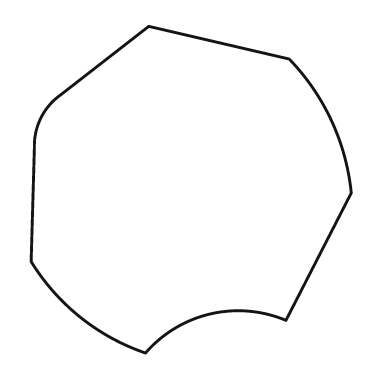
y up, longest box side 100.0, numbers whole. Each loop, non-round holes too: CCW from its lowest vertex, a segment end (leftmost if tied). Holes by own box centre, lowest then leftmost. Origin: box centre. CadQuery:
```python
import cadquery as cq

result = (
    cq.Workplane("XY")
    .moveTo(-14.0, -50.0)
    .threePointArc((6.0, -38.0), (29.0, -40.0))
    .lineTo(49.0, -1.0)
    .threePointArc((43.0, 21.0), (30.0, 40.0))
    .lineTo(-13.0, 50.0)
    .lineTo(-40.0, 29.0)
    .threePointArc((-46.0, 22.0), (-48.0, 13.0))
    .lineTo(-49.0, -22.0)
    .threePointArc((-34.0, -39.0), (-14.0, -50.0))
    .close()
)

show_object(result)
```